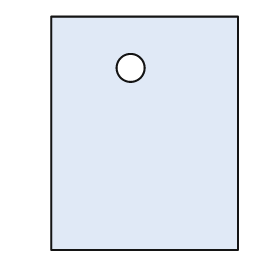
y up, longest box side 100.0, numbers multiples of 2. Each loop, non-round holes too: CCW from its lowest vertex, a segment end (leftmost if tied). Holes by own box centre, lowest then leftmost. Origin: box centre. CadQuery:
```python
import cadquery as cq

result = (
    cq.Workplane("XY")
    .moveTo(-40.0, -50.0)
    .lineTo(40.0, -50.0)
    .lineTo(40.0, 50.0)
    .lineTo(-40.0, 50.0)
    .close()
    .moveTo(-6.0, 28.0)
    .circle(6.0)
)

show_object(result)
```